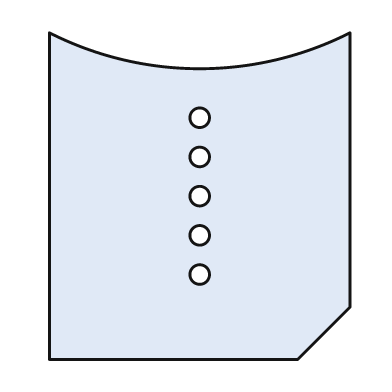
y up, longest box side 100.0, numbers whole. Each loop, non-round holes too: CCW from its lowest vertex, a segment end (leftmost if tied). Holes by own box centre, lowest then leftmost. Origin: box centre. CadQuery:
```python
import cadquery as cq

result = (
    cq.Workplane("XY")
    .moveTo(-46.0, -50.0)
    .lineTo(30.0, -50.0)
    .lineTo(46.0, -34.0)
    .lineTo(46.0, 50.0)
    .threePointArc((0.0, 39.0), (-46.0, 50.0))
    .close()
    .moveTo(0.0, -24.0)
    .circle(3.0)
    .moveTo(0.0, -12.0)
    .circle(3.0)
    .moveTo(0.0, 0.0)
    .circle(3.0)
    .moveTo(0.0, 12.0)
    .circle(3.0)
    .moveTo(0.0, 24.0)
    .circle(3.0)
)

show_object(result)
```